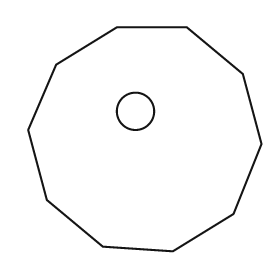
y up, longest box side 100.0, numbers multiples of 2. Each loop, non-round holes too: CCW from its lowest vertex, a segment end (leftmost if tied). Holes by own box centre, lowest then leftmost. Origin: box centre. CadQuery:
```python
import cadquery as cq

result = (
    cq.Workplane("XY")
    .moveTo(12.0, -48.0)
    .lineTo(38.0, -32.0)
    .lineTo(50.0, -2.0)
    .lineTo(42.0, 28.0)
    .lineTo(18.0, 48.0)
    .lineTo(-12.0, 48.0)
    .lineTo(-38.0, 32.0)
    .lineTo(-50.0, 4.0)
    .lineTo(-42.0, -26.0)
    .lineTo(-18.0, -46.0)
    .close()
    .moveTo(-4.0, 12.0)
    .circle(8.0)
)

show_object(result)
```